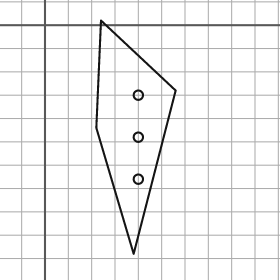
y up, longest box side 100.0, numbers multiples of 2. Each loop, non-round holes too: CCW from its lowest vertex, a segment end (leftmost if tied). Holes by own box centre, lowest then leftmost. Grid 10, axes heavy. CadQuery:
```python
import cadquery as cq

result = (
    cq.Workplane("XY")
    .moveTo(38.0, -98.0)
    .lineTo(56.0, -28.0)
    .lineTo(24.0, 2.0)
    .lineTo(22.0, -44.0)
    .close()
    .moveTo(40.0, -66.0)
    .circle(2.0)
    .moveTo(40.0, -48.0)
    .circle(2.0)
    .moveTo(40.0, -30.0)
    .circle(2.0)
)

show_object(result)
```